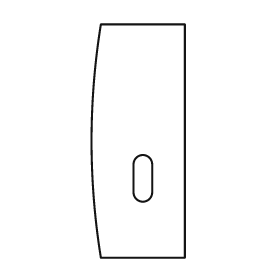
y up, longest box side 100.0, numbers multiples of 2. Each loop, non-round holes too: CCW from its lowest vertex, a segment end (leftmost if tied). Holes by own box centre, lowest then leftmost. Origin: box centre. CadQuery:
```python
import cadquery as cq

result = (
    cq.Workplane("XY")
    .moveTo(-16.0, -50.0)
    .lineTo(20.0, -50.0)
    .lineTo(20.0, 50.0)
    .lineTo(-16.0, 50.0)
    .threePointArc((-20.0, 0.0), (-16.0, -50.0))
    .close()
    .moveTo(-2.0, -22.0)
    .threePointArc((2.0, -26.0), (6.0, -22.0))
    .lineTo(6.0, -10.0)
    .threePointArc((2.0, -6.0), (-2.0, -10.0))
    .close()
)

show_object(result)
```